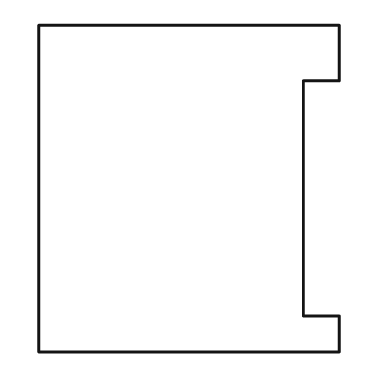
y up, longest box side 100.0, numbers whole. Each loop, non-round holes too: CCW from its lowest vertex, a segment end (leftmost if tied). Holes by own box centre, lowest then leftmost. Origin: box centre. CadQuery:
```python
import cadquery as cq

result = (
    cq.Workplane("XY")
    .moveTo(-46.0, -50.0)
    .lineTo(46.0, -50.0)
    .lineTo(46.0, -39.0)
    .lineTo(35.0, -39.0)
    .lineTo(35.0, 33.0)
    .lineTo(46.0, 33.0)
    .lineTo(46.0, 50.0)
    .lineTo(-46.0, 50.0)
    .close()
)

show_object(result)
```